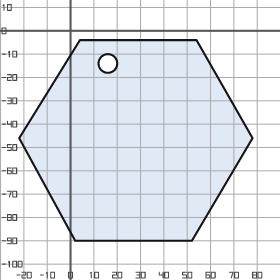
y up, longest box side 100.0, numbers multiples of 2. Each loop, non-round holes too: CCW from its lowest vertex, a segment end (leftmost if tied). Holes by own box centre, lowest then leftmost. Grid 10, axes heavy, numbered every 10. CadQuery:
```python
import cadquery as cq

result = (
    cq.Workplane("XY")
    .moveTo(2.0, -90.0)
    .lineTo(52.0, -90.0)
    .lineTo(78.0, -46.0)
    .lineTo(54.0, -4.0)
    .lineTo(4.0, -4.0)
    .lineTo(-22.0, -46.0)
    .close()
    .moveTo(16.0, -14.0)
    .circle(4.0)
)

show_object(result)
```